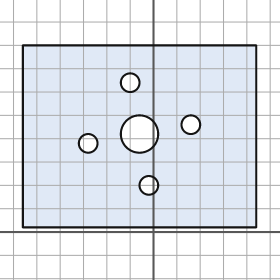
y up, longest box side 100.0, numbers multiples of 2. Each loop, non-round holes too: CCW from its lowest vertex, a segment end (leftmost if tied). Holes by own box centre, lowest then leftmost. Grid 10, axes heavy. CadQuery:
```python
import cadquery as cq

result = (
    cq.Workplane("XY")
    .moveTo(-56.0, 2.0)
    .lineTo(44.0, 2.0)
    .lineTo(44.0, 80.0)
    .lineTo(-56.0, 80.0)
    .close()
    .moveTo(-2.0, 20.0)
    .circle(4.0)
    .moveTo(-28.0, 38.0)
    .circle(4.0)
    .moveTo(-6.0, 42.0)
    .circle(8.0)
    .moveTo(16.0, 46.0)
    .circle(4.0)
    .moveTo(-10.0, 64.0)
    .circle(4.0)
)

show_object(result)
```